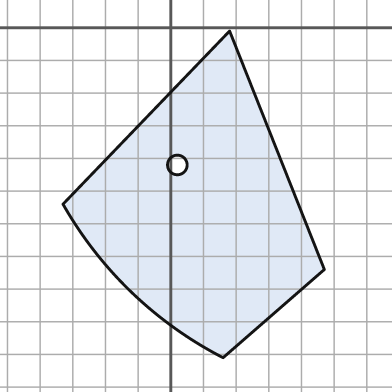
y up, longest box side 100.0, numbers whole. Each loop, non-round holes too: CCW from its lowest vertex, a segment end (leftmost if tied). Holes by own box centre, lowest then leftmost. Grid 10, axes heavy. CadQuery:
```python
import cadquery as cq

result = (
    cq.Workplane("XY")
    .moveTo(16.0, -101.0)
    .lineTo(47.0, -74.0)
    .lineTo(18.0, -1.0)
    .lineTo(-33.0, -54.0)
    .threePointArc((-12.0, -81.0), (16.0, -101.0))
    .close()
    .moveTo(2.0, -42.0)
    .circle(3.0)
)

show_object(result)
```